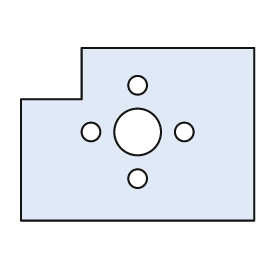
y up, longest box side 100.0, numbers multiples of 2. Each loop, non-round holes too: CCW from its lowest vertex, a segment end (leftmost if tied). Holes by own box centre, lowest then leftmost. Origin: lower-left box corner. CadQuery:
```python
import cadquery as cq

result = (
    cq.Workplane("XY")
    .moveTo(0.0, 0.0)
    .lineTo(100.0, 0.0)
    .lineTo(100.0, 74.0)
    .lineTo(26.0, 74.0)
    .lineTo(26.0, 52.0)
    .lineTo(0.0, 52.0)
    .close()
    .moveTo(50.0, 18.0)
    .circle(4.0)
    .moveTo(30.0, 38.0)
    .circle(4.0)
    .moveTo(50.0, 38.0)
    .circle(10.0)
    .moveTo(70.0, 38.0)
    .circle(4.0)
    .moveTo(50.0, 58.0)
    .circle(4.0)
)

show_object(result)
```